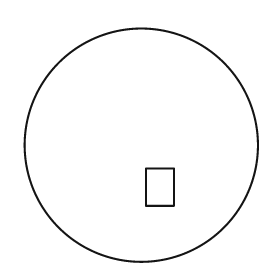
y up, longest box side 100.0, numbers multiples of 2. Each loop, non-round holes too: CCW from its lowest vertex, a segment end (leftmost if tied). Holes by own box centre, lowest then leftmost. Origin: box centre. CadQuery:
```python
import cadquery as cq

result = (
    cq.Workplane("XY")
    .moveTo(0.0, 0.0)
    .circle(50.0)
    .moveTo(2.0, -26.0)
    .lineTo(14.0, -26.0)
    .lineTo(14.0, -10.0)
    .lineTo(2.0, -10.0)
    .close()
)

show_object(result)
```